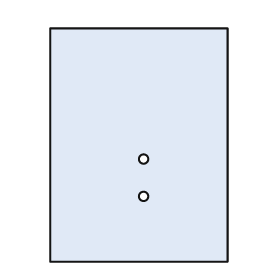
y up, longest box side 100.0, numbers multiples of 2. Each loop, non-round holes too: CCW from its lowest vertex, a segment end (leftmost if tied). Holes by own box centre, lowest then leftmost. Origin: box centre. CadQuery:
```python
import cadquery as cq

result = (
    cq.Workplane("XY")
    .moveTo(-38.0, -50.0)
    .lineTo(38.0, -50.0)
    .lineTo(38.0, 50.0)
    .lineTo(-38.0, 50.0)
    .close()
    .moveTo(2.0, -22.0)
    .circle(2.0)
    .moveTo(2.0, -6.0)
    .circle(2.0)
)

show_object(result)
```